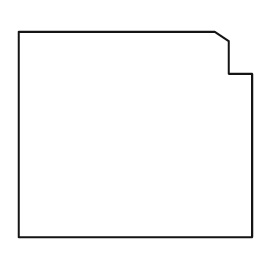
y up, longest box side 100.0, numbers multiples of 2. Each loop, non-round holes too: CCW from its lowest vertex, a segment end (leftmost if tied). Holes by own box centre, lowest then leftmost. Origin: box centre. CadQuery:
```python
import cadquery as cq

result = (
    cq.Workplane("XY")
    .moveTo(-50.0, -44.0)
    .lineTo(50.0, -44.0)
    .lineTo(50.0, 26.0)
    .lineTo(40.0, 26.0)
    .lineTo(40.0, 40.0)
    .lineTo(34.0, 44.0)
    .lineTo(-50.0, 44.0)
    .close()
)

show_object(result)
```